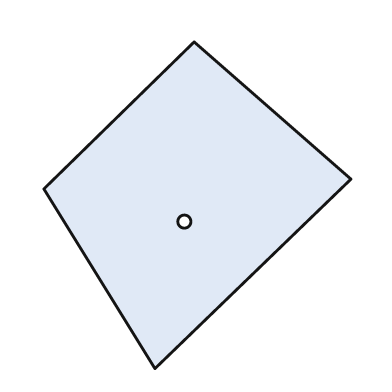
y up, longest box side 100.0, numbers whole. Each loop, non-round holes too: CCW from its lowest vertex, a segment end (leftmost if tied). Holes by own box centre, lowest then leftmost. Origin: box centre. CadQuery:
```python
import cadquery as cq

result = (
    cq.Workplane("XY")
    .moveTo(-13.0, -50.0)
    .lineTo(47.0, 8.0)
    .lineTo(-1.0, 50.0)
    .lineTo(-47.0, 5.0)
    .close()
    .moveTo(-4.0, -5.0)
    .circle(2.0)
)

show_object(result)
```